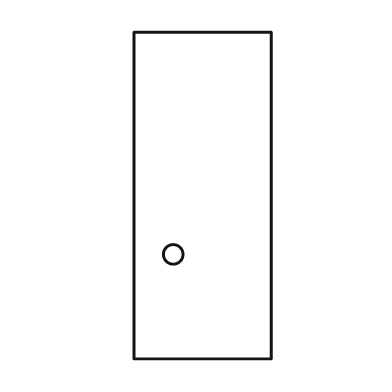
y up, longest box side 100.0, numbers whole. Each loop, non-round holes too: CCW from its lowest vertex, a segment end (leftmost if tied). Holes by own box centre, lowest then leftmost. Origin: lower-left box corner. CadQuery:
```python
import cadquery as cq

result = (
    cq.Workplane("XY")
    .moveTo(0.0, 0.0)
    .lineTo(42.0, 0.0)
    .lineTo(42.0, 100.0)
    .lineTo(0.0, 100.0)
    .close()
    .moveTo(12.0, 32.0)
    .circle(3.0)
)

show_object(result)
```